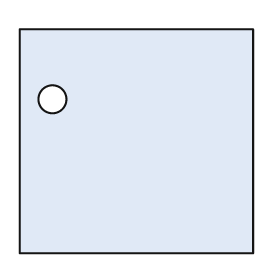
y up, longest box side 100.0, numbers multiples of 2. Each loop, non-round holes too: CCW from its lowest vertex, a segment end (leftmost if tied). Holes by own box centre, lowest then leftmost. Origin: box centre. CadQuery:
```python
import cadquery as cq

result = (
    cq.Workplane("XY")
    .moveTo(-50.0, -48.0)
    .lineTo(50.0, -48.0)
    .lineTo(50.0, 48.0)
    .lineTo(-50.0, 48.0)
    .close()
    .moveTo(-36.0, 18.0)
    .circle(6.0)
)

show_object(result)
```